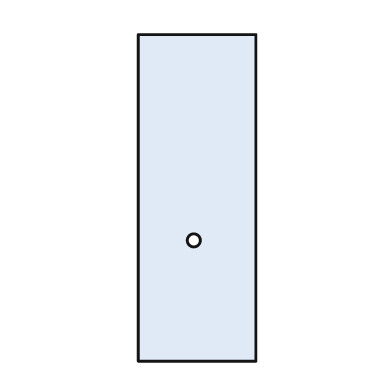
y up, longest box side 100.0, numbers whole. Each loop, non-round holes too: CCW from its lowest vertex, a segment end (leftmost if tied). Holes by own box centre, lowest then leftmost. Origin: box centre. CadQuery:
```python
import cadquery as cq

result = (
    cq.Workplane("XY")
    .moveTo(-18.0, -50.0)
    .lineTo(18.0, -50.0)
    .lineTo(18.0, 50.0)
    .lineTo(-18.0, 50.0)
    .close()
    .moveTo(-1.0, -13.0)
    .circle(2.0)
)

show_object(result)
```